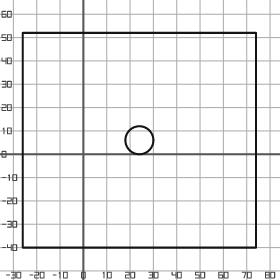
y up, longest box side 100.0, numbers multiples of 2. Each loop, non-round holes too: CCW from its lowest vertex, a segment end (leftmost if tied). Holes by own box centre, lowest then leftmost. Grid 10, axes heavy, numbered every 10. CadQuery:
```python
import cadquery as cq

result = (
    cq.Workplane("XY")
    .moveTo(-26.0, -40.0)
    .lineTo(74.0, -40.0)
    .lineTo(74.0, 52.0)
    .lineTo(-26.0, 52.0)
    .close()
    .moveTo(24.0, 6.0)
    .circle(6.0)
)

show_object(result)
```